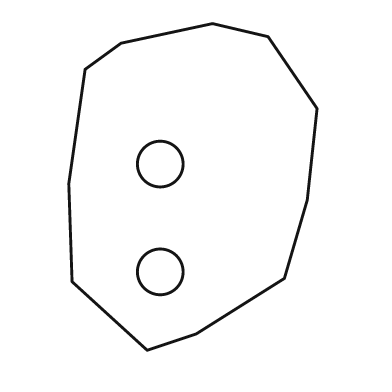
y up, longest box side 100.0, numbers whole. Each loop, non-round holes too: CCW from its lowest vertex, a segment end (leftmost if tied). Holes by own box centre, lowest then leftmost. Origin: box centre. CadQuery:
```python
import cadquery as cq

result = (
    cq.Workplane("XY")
    .moveTo(-14.0, -50.0)
    .lineTo(1.0, -45.0)
    .lineTo(28.0, -28.0)
    .lineTo(35.0, -4.0)
    .lineTo(38.0, 24.0)
    .lineTo(23.0, 46.0)
    .lineTo(6.0, 50.0)
    .lineTo(-22.0, 44.0)
    .lineTo(-33.0, 36.0)
    .lineTo(-38.0, 1.0)
    .lineTo(-37.0, -29.0)
    .close()
    .moveTo(-10.0, -26.0)
    .circle(7.0)
    .moveTo(-10.0, 7.0)
    .circle(7.0)
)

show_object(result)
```